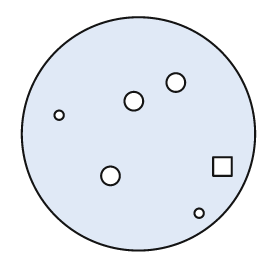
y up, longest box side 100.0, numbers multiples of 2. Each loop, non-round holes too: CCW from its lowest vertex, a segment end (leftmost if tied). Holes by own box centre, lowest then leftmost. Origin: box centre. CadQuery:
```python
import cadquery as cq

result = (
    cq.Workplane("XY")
    .moveTo(0.0, 0.0)
    .circle(50.0)
    .moveTo(26.0, -34.0)
    .circle(2.0)
    .moveTo(-12.0, -18.0)
    .circle(4.0)
    .moveTo(32.0, -18.0)
    .lineTo(40.0, -18.0)
    .lineTo(40.0, -10.0)
    .lineTo(32.0, -10.0)
    .close()
    .moveTo(-34.0, 8.0)
    .circle(2.0)
    .moveTo(-2.0, 14.0)
    .circle(4.0)
    .moveTo(16.0, 22.0)
    .circle(4.0)
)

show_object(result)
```